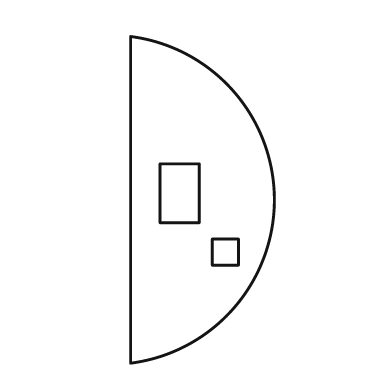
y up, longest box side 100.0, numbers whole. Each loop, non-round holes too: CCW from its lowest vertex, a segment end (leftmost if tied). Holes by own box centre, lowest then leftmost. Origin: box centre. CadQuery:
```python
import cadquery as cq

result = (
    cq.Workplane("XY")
    .moveTo(-22.0, -50.0)
    .threePointArc((22.0, 0.0), (-22.0, 50.0))
    .close()
    .moveTo(3.0, -20.0)
    .lineTo(11.0, -20.0)
    .lineTo(11.0, -12.0)
    .lineTo(3.0, -12.0)
    .close()
    .moveTo(-13.0, -7.0)
    .lineTo(-1.0, -7.0)
    .lineTo(-1.0, 11.0)
    .lineTo(-13.0, 11.0)
    .close()
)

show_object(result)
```